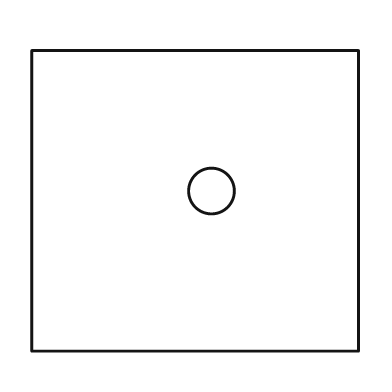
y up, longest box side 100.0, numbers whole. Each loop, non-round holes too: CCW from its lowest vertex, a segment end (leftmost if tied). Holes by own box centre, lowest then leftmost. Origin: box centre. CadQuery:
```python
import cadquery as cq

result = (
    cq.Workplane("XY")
    .moveTo(-50.0, -46.0)
    .lineTo(50.0, -46.0)
    .lineTo(50.0, 46.0)
    .lineTo(-50.0, 46.0)
    .close()
    .moveTo(5.0, 3.0)
    .circle(7.0)
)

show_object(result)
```